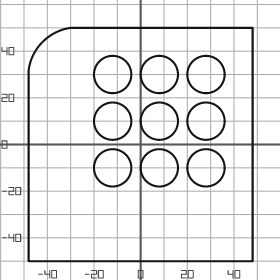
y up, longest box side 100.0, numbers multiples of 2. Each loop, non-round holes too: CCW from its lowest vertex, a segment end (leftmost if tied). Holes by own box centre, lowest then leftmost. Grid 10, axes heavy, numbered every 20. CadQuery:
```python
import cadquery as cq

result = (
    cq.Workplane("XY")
    .moveTo(-48.0, -50.0)
    .lineTo(48.0, -50.0)
    .lineTo(48.0, 50.0)
    .lineTo(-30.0, 50.0)
    .threePointArc((-42.0, 44.0), (-48.0, 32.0))
    .close()
    .moveTo(-12.0, -10.0)
    .circle(8.0)
    .moveTo(8.0, -10.0)
    .circle(8.0)
    .moveTo(28.0, -10.0)
    .circle(8.0)
    .moveTo(-12.0, 10.0)
    .circle(8.0)
    .moveTo(8.0, 10.0)
    .circle(8.0)
    .moveTo(28.0, 10.0)
    .circle(8.0)
    .moveTo(-12.0, 30.0)
    .circle(8.0)
    .moveTo(8.0, 30.0)
    .circle(8.0)
    .moveTo(28.0, 30.0)
    .circle(8.0)
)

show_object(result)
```